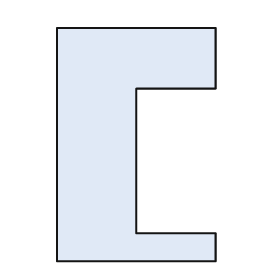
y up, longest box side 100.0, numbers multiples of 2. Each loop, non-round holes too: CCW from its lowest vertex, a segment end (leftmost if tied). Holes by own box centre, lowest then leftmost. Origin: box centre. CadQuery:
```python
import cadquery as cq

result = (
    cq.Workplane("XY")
    .moveTo(-34.0, -50.0)
    .lineTo(34.0, -50.0)
    .lineTo(34.0, -38.0)
    .lineTo(0.0, -38.0)
    .lineTo(0.0, 24.0)
    .lineTo(34.0, 24.0)
    .lineTo(34.0, 50.0)
    .lineTo(-34.0, 50.0)
    .close()
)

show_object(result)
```